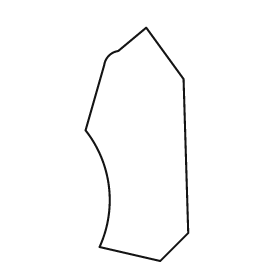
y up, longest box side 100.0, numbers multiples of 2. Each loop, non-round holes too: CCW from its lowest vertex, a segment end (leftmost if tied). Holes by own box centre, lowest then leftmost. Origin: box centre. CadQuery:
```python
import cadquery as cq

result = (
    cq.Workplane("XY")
    .moveTo(10.0, -50.0)
    .lineTo(22.0, -38.0)
    .lineTo(20.0, 28.0)
    .lineTo(4.0, 50.0)
    .lineTo(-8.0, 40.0)
    .threePointArc((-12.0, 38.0), (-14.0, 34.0))
    .lineTo(-22.0, 6.0)
    .threePointArc((-12.0, -18.0), (-16.0, -44.0))
    .close()
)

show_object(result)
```